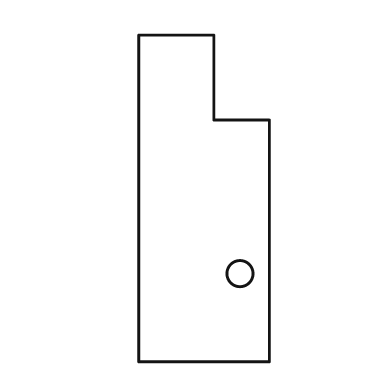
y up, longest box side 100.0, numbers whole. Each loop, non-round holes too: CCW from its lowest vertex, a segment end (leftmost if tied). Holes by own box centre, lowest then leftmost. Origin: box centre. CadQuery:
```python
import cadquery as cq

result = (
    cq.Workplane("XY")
    .moveTo(-20.0, -50.0)
    .lineTo(20.0, -50.0)
    .lineTo(20.0, 24.0)
    .lineTo(3.0, 24.0)
    .lineTo(3.0, 50.0)
    .lineTo(-20.0, 50.0)
    .close()
    .moveTo(11.0, -23.0)
    .circle(4.0)
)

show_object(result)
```